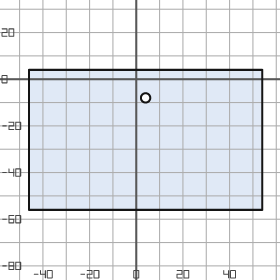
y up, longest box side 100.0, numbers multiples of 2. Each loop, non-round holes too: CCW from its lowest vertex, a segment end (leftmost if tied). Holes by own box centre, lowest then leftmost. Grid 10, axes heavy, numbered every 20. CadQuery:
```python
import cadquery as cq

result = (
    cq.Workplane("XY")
    .moveTo(-46.0, -56.0)
    .lineTo(54.0, -56.0)
    .lineTo(54.0, 4.0)
    .lineTo(-46.0, 4.0)
    .close()
    .moveTo(4.0, -8.0)
    .circle(2.0)
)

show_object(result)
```